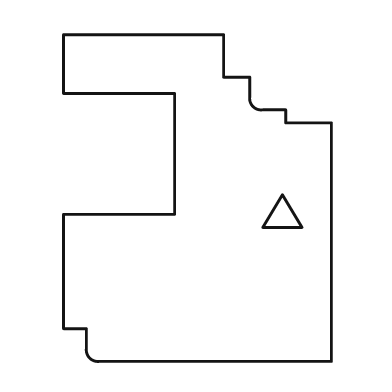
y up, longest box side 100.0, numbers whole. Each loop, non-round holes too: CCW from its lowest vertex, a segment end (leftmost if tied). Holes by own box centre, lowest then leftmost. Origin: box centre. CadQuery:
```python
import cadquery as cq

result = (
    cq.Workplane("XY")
    .moveTo(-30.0, -50.0)
    .lineTo(41.0, -50.0)
    .lineTo(41.0, 23.0)
    .lineTo(27.0, 23.0)
    .lineTo(27.0, 27.0)
    .lineTo(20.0, 27.0)
    .threePointArc((17.0, 28.0), (16.0, 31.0))
    .lineTo(16.0, 37.0)
    .lineTo(8.0, 37.0)
    .lineTo(8.0, 50.0)
    .lineTo(-41.0, 50.0)
    .lineTo(-41.0, 32.0)
    .lineTo(-7.0, 32.0)
    .lineTo(-7.0, -5.0)
    .lineTo(-41.0, -5.0)
    .lineTo(-41.0, -40.0)
    .lineTo(-34.0, -40.0)
    .lineTo(-34.0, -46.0)
    .threePointArc((-33.0, -49.0), (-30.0, -50.0))
    .close()
    .moveTo(20.0, -9.0)
    .lineTo(32.0, -9.0)
    .lineTo(26.0, 1.0)
    .close()
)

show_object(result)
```